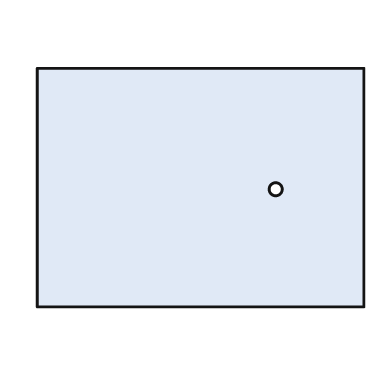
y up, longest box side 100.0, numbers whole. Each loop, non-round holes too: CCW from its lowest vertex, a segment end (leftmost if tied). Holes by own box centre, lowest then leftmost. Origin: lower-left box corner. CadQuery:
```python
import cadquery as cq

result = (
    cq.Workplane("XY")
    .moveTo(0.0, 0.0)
    .lineTo(100.0, 0.0)
    .lineTo(100.0, 73.0)
    .lineTo(0.0, 73.0)
    .close()
    .moveTo(73.0, 36.0)
    .circle(2.0)
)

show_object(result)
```